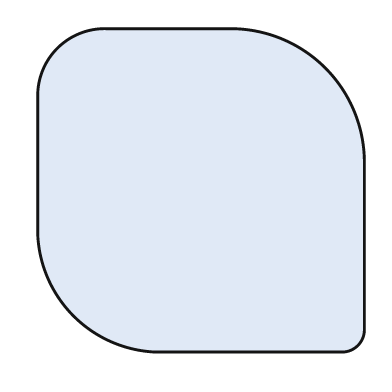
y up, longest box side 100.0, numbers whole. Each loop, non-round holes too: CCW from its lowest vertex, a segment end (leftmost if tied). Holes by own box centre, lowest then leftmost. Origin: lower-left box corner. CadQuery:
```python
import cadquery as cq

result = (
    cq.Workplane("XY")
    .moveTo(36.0, 0.0)
    .lineTo(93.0, 0.0)
    .threePointArc((98.0, 2.0), (100.0, 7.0))
    .lineTo(100.0, 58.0)
    .threePointArc((88.0, 87.0), (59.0, 99.0))
    .lineTo(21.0, 99.0)
    .threePointArc((6.0, 93.0), (0.0, 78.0))
    .lineTo(0.0, 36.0)
    .threePointArc((11.0, 11.0), (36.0, 0.0))
    .close()
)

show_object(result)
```